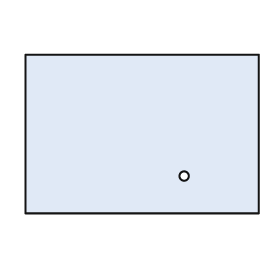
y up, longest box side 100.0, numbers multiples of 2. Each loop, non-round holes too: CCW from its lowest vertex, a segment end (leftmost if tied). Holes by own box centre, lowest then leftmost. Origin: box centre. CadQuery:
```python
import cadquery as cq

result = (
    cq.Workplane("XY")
    .moveTo(-50.0, -34.0)
    .lineTo(50.0, -34.0)
    .lineTo(50.0, 34.0)
    .lineTo(-50.0, 34.0)
    .close()
    .moveTo(18.0, -18.0)
    .circle(2.0)
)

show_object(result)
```